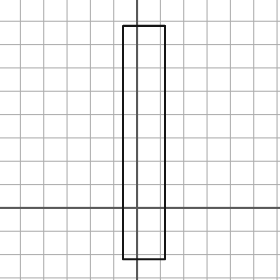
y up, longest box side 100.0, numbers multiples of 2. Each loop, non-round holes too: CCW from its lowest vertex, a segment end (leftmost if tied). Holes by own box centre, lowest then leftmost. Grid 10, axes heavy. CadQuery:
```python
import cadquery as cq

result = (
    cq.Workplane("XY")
    .moveTo(-6.0, -22.0)
    .lineTo(12.0, -22.0)
    .lineTo(12.0, 78.0)
    .lineTo(-6.0, 78.0)
    .close()
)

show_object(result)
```